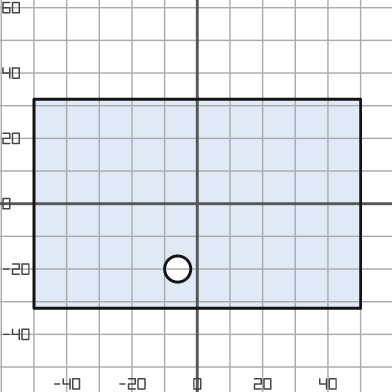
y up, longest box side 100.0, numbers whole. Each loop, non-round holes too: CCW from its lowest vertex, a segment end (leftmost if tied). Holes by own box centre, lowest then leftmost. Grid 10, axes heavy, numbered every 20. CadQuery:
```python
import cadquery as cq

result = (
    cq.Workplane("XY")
    .moveTo(-50.0, -32.0)
    .lineTo(50.0, -32.0)
    .lineTo(50.0, 32.0)
    .lineTo(-50.0, 32.0)
    .close()
    .moveTo(-6.0, -20.0)
    .circle(4.0)
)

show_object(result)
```